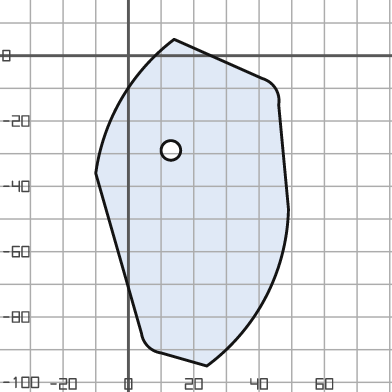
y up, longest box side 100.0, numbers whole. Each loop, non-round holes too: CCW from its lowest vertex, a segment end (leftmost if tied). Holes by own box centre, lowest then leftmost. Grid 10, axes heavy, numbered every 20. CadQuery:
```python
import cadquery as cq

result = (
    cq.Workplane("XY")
    .moveTo(24.0, -95.0)
    .threePointArc((42.0, -74.0), (49.0, -47.0))
    .lineTo(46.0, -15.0)
    .threePointArc((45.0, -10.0), (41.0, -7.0))
    .lineTo(14.0, 5.0)
    .threePointArc((-2.0, -13.0), (-10.0, -36.0))
    .lineTo(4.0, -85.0)
    .threePointArc((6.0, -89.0), (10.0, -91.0))
    .close()
    .moveTo(13.0, -29.0)
    .circle(3.0)
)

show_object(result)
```